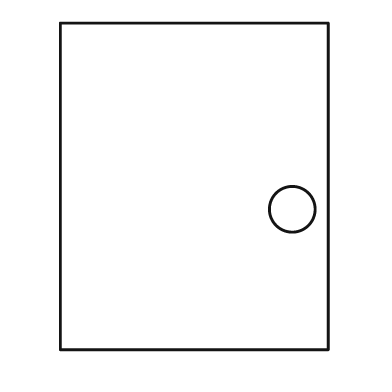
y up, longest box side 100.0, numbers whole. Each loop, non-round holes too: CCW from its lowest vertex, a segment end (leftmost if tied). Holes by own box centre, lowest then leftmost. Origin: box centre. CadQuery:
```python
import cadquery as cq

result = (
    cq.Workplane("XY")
    .moveTo(-41.0, -50.0)
    .lineTo(41.0, -50.0)
    .lineTo(41.0, 50.0)
    .lineTo(-41.0, 50.0)
    .close()
    .moveTo(30.0, -7.0)
    .circle(7.0)
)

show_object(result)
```